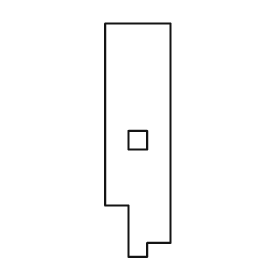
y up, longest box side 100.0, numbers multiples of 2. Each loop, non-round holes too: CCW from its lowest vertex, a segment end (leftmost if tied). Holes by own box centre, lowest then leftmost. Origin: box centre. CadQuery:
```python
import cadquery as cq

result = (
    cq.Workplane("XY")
    .moveTo(-4.0, -50.0)
    .lineTo(4.0, -50.0)
    .lineTo(4.0, -44.0)
    .lineTo(14.0, -44.0)
    .lineTo(14.0, 50.0)
    .lineTo(-14.0, 50.0)
    .lineTo(-14.0, -28.0)
    .lineTo(-4.0, -28.0)
    .close()
    .moveTo(-4.0, -4.0)
    .lineTo(4.0, -4.0)
    .lineTo(4.0, 4.0)
    .lineTo(-4.0, 4.0)
    .close()
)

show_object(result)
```